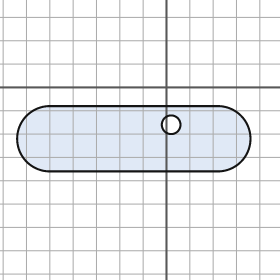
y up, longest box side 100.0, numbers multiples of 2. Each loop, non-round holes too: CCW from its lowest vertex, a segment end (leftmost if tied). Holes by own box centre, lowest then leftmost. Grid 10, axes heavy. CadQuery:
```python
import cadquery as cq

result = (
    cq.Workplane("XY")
    .moveTo(-50.0, -36.0)
    .lineTo(22.0, -36.0)
    .threePointArc((36.0, -22.0), (22.0, -8.0))
    .lineTo(-50.0, -8.0)
    .threePointArc((-64.0, -22.0), (-50.0, -36.0))
    .close()
    .moveTo(2.0, -16.0)
    .circle(4.0)
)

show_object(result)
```